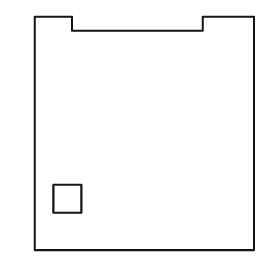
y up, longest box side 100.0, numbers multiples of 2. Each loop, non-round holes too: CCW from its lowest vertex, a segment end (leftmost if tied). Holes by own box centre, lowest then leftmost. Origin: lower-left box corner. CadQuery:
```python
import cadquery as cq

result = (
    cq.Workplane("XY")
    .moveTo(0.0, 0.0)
    .lineTo(94.0, 0.0)
    .lineTo(94.0, 100.0)
    .lineTo(72.0, 100.0)
    .lineTo(72.0, 94.0)
    .lineTo(16.0, 94.0)
    .lineTo(16.0, 100.0)
    .lineTo(0.0, 100.0)
    .close()
    .moveTo(8.0, 16.0)
    .lineTo(20.0, 16.0)
    .lineTo(20.0, 28.0)
    .lineTo(8.0, 28.0)
    .close()
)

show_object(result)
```